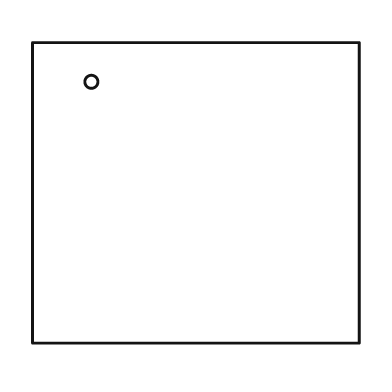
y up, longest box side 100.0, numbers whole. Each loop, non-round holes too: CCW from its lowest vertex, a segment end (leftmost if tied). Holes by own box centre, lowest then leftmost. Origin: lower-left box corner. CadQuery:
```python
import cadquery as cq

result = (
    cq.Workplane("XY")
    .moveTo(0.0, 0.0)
    .lineTo(100.0, 0.0)
    .lineTo(100.0, 92.0)
    .lineTo(0.0, 92.0)
    .close()
    .moveTo(18.0, 80.0)
    .circle(2.0)
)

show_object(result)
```